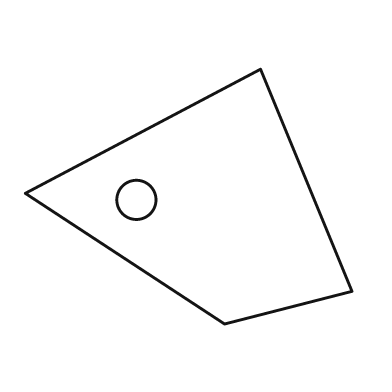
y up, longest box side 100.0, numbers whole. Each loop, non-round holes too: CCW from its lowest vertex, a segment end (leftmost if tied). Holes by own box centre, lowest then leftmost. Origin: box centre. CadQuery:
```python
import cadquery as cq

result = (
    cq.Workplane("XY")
    .moveTo(11.0, -39.0)
    .lineTo(50.0, -29.0)
    .lineTo(22.0, 39.0)
    .lineTo(-50.0, 1.0)
    .close()
    .moveTo(-16.0, -1.0)
    .circle(6.0)
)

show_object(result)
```